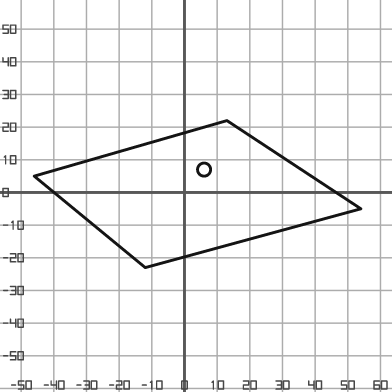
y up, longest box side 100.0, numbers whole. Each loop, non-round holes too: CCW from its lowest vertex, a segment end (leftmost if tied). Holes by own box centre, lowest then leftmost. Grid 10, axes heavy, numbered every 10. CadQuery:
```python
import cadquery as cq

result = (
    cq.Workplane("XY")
    .moveTo(-12.0, -23.0)
    .lineTo(54.0, -5.0)
    .lineTo(13.0, 22.0)
    .lineTo(-46.0, 5.0)
    .close()
    .moveTo(6.0, 7.0)
    .circle(2.0)
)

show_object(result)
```